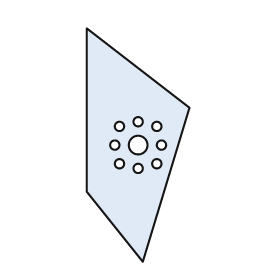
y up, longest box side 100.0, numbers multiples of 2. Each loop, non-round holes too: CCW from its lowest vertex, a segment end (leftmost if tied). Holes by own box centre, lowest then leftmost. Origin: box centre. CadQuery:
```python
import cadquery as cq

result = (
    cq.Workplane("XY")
    .moveTo(2.0, -50.0)
    .lineTo(22.0, 16.0)
    .lineTo(-22.0, 50.0)
    .lineTo(-22.0, -20.0)
    .close()
    .moveTo(0.0, -10.0)
    .circle(2.0)
    .moveTo(-8.0, -8.0)
    .circle(2.0)
    .moveTo(8.0, -8.0)
    .circle(2.0)
    .moveTo(-10.0, 0.0)
    .circle(2.0)
    .moveTo(0.0, 0.0)
    .circle(4.0)
    .moveTo(10.0, 0.0)
    .circle(2.0)
    .moveTo(-8.0, 8.0)
    .circle(2.0)
    .moveTo(8.0, 8.0)
    .circle(2.0)
    .moveTo(0.0, 10.0)
    .circle(2.0)
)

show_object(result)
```